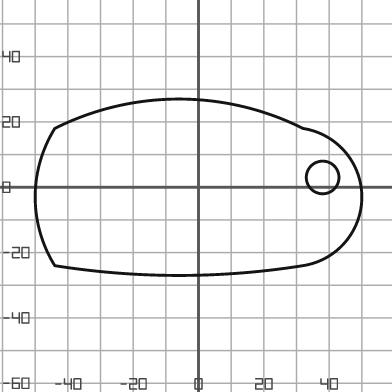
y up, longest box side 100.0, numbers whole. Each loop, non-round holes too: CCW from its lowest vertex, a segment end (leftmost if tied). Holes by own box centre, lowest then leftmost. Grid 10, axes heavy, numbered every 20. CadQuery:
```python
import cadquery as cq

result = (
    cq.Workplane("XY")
    .moveTo(-44.0, -24.0)
    .threePointArc((-6.0, -27.0), (32.0, -24.0))
    .threePointArc((50.0, -3.0), (32.0, 18.0))
    .threePointArc((-6.0, 27.0), (-44.0, 18.0))
    .threePointArc((-50.0, -3.0), (-44.0, -24.0))
    .close()
    .moveTo(38.0, 3.0)
    .circle(5.0)
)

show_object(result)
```